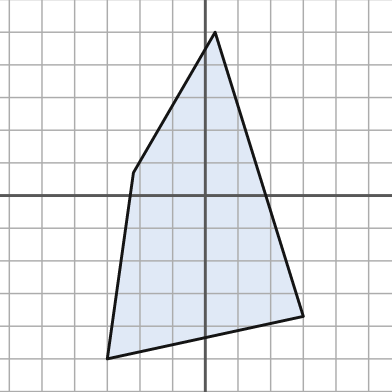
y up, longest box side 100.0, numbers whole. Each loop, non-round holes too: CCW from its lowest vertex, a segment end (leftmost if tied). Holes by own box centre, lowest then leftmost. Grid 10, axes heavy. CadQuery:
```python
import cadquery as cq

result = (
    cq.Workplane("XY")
    .moveTo(-30.0, -50.0)
    .lineTo(30.0, -37.0)
    .lineTo(3.0, 50.0)
    .lineTo(-22.0, 7.0)
    .close()
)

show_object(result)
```